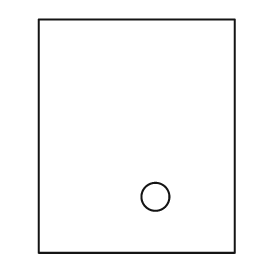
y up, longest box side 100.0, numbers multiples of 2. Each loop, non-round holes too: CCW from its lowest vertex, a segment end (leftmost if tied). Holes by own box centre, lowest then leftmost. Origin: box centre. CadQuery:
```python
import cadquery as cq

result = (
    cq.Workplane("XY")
    .moveTo(-42.0, -50.0)
    .lineTo(42.0, -50.0)
    .lineTo(42.0, 50.0)
    .lineTo(-42.0, 50.0)
    .close()
    .moveTo(8.0, -26.0)
    .circle(6.0)
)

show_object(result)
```